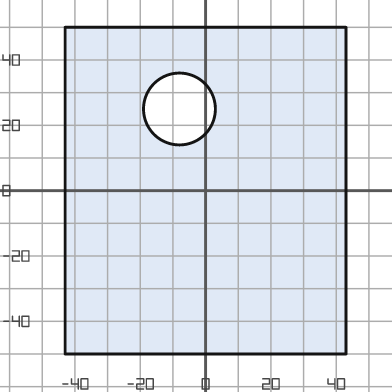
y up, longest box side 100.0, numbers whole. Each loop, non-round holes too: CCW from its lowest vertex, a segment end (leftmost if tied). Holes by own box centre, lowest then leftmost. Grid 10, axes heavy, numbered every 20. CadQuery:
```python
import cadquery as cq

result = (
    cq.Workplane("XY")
    .moveTo(-43.0, -50.0)
    .lineTo(43.0, -50.0)
    .lineTo(43.0, 50.0)
    .lineTo(-43.0, 50.0)
    .close()
    .moveTo(-8.0, 25.0)
    .circle(11.0)
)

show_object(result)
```